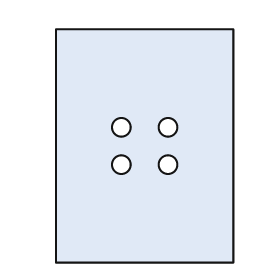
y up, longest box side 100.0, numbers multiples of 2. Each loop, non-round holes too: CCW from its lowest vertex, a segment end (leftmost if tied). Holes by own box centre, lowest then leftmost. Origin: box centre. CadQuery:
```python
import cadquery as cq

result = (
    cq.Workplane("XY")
    .moveTo(-38.0, -50.0)
    .lineTo(38.0, -50.0)
    .lineTo(38.0, 50.0)
    .lineTo(-38.0, 50.0)
    .close()
    .moveTo(-10.0, -8.0)
    .circle(4.0)
    .moveTo(10.0, -8.0)
    .circle(4.0)
    .moveTo(-10.0, 8.0)
    .circle(4.0)
    .moveTo(10.0, 8.0)
    .circle(4.0)
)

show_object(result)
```